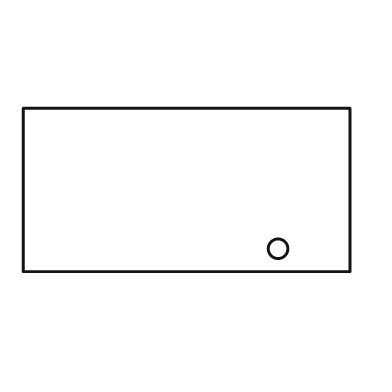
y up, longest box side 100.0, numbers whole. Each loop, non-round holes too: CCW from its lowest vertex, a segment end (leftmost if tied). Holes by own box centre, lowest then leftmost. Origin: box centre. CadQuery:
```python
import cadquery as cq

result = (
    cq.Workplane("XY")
    .moveTo(-50.0, -25.0)
    .lineTo(50.0, -25.0)
    .lineTo(50.0, 25.0)
    .lineTo(-50.0, 25.0)
    .close()
    .moveTo(28.0, -18.0)
    .circle(3.0)
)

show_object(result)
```